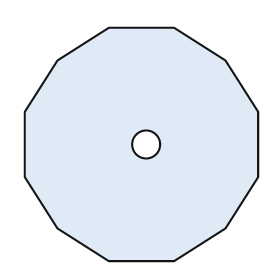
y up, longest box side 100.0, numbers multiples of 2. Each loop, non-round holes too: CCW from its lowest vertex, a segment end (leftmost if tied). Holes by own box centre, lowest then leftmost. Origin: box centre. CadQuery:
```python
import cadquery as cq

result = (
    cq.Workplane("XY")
    .moveTo(-14.0, -50.0)
    .lineTo(14.0, -50.0)
    .lineTo(36.0, -36.0)
    .lineTo(50.0, -14.0)
    .lineTo(50.0, 14.0)
    .lineTo(36.0, 36.0)
    .lineTo(14.0, 50.0)
    .lineTo(-14.0, 50.0)
    .lineTo(-36.0, 36.0)
    .lineTo(-50.0, 14.0)
    .lineTo(-50.0, -14.0)
    .lineTo(-36.0, -36.0)
    .close()
    .moveTo(2.0, 0.0)
    .circle(6.0)
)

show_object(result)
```